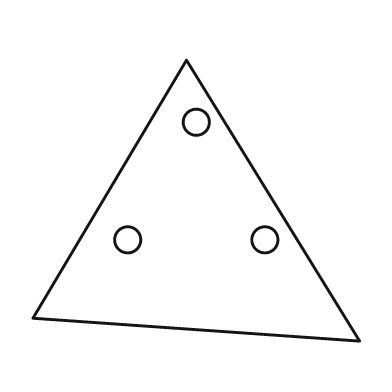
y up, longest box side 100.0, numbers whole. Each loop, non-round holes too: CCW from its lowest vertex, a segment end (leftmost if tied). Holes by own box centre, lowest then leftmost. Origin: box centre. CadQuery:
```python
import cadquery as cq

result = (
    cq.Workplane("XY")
    .moveTo(50.0, -43.0)
    .lineTo(-3.0, 43.0)
    .lineTo(-50.0, -36.0)
    .close()
    .moveTo(-21.0, -12.0)
    .circle(4.0)
    .moveTo(21.0, -12.0)
    .circle(4.0)
    .moveTo(0.0, 24.0)
    .circle(4.0)
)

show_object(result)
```